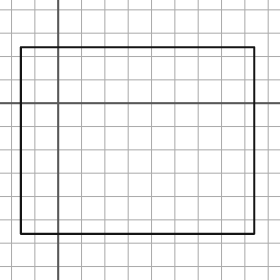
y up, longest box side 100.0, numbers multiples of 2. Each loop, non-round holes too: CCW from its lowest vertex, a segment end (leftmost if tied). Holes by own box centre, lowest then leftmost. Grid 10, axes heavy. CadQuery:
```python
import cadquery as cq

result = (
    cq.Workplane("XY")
    .moveTo(-16.0, -56.0)
    .lineTo(84.0, -56.0)
    .lineTo(84.0, 24.0)
    .lineTo(-16.0, 24.0)
    .close()
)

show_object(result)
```